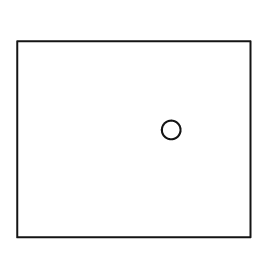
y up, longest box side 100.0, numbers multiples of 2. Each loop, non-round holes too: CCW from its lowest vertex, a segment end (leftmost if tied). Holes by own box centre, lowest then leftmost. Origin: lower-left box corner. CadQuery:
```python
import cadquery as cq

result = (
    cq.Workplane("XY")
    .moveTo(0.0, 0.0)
    .lineTo(100.0, 0.0)
    .lineTo(100.0, 84.0)
    .lineTo(0.0, 84.0)
    .close()
    .moveTo(66.0, 46.0)
    .circle(4.0)
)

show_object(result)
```